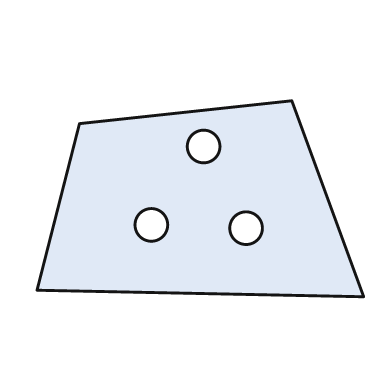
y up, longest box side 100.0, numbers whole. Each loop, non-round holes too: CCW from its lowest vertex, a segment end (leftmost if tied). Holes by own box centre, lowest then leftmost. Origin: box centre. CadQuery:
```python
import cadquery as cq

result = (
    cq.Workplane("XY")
    .moveTo(50.0, -30.0)
    .lineTo(28.0, 30.0)
    .lineTo(-37.0, 23.0)
    .lineTo(-50.0, -28.0)
    .close()
    .moveTo(14.0, -9.0)
    .circle(5.0)
    .moveTo(-15.0, -8.0)
    .circle(5.0)
    .moveTo(1.0, 16.0)
    .circle(5.0)
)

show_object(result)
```